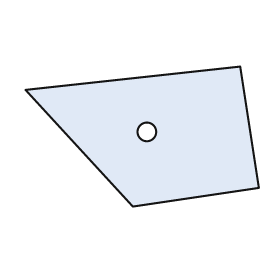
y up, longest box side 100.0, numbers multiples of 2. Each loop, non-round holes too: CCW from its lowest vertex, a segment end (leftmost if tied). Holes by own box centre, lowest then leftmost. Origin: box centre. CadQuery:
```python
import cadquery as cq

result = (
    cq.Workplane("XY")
    .moveTo(-4.0, -30.0)
    .lineTo(50.0, -22.0)
    .lineTo(42.0, 30.0)
    .lineTo(-50.0, 20.0)
    .close()
    .moveTo(2.0, 2.0)
    .circle(4.0)
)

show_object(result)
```